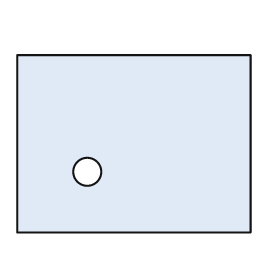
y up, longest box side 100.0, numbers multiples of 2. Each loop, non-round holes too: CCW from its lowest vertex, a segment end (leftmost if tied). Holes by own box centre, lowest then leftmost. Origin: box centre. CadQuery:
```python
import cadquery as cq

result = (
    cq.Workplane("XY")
    .moveTo(-50.0, -38.0)
    .lineTo(50.0, -38.0)
    .lineTo(50.0, 38.0)
    .lineTo(-50.0, 38.0)
    .close()
    .moveTo(-20.0, -12.0)
    .circle(6.0)
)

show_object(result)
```